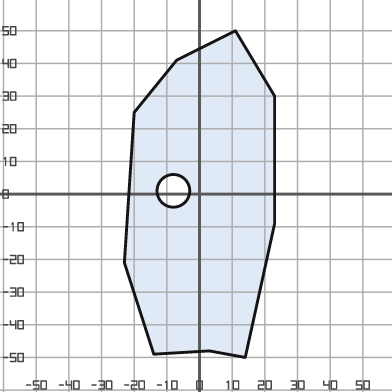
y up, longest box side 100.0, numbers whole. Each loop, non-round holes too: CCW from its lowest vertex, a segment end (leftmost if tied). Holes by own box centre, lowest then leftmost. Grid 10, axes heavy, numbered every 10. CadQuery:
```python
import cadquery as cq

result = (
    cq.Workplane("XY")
    .moveTo(14.0, -50.0)
    .lineTo(23.0, -9.0)
    .lineTo(23.0, 30.0)
    .lineTo(11.0, 50.0)
    .lineTo(-7.0, 41.0)
    .lineTo(-20.0, 25.0)
    .lineTo(-23.0, -21.0)
    .lineTo(-14.0, -49.0)
    .lineTo(3.0, -48.0)
    .close()
    .moveTo(-8.0, 1.0)
    .circle(5.0)
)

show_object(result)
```